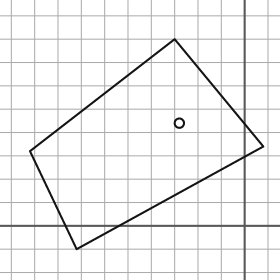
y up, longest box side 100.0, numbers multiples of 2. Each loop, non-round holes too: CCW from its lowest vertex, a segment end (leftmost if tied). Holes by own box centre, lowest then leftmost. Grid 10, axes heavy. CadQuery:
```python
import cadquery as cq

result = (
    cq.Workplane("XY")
    .moveTo(-72.0, -10.0)
    .lineTo(8.0, 34.0)
    .lineTo(-30.0, 80.0)
    .lineTo(-92.0, 32.0)
    .close()
    .moveTo(-28.0, 44.0)
    .circle(2.0)
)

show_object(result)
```